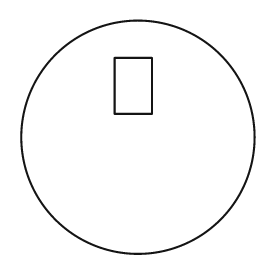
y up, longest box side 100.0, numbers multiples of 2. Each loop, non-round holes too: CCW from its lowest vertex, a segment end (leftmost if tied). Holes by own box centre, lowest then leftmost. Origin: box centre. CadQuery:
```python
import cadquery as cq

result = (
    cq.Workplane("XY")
    .moveTo(0.0, 0.0)
    .circle(50.0)
    .moveTo(-10.0, 10.0)
    .lineTo(6.0, 10.0)
    .lineTo(6.0, 34.0)
    .lineTo(-10.0, 34.0)
    .close()
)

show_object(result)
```